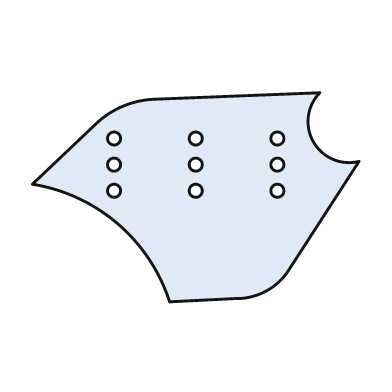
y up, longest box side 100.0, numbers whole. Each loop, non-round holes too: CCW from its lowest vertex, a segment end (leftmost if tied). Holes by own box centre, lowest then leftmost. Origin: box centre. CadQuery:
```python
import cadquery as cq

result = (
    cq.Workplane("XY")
    .moveTo(-8.0, -32.0)
    .lineTo(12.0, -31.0)
    .threePointArc((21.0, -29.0), (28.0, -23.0))
    .lineTo(50.0, 11.0)
    .threePointArc((36.0, 17.0), (38.0, 32.0))
    .lineTo(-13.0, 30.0)
    .threePointArc((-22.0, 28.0), (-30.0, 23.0))
    .lineTo(-50.0, 4.0)
    .threePointArc((-24.0, -8.0), (-8.0, -32.0))
    .close()
    .moveTo(-25.0, 2.0)
    .circle(2.0)
    .moveTo(0.0, 2.0)
    .circle(2.0)
    .moveTo(25.0, 2.0)
    .circle(2.0)
    .moveTo(-25.0, 10.0)
    .circle(2.0)
    .moveTo(0.0, 10.0)
    .circle(2.0)
    .moveTo(25.0, 10.0)
    .circle(2.0)
    .moveTo(-25.0, 18.0)
    .circle(2.0)
    .moveTo(0.0, 18.0)
    .circle(2.0)
    .moveTo(25.0, 18.0)
    .circle(2.0)
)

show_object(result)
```